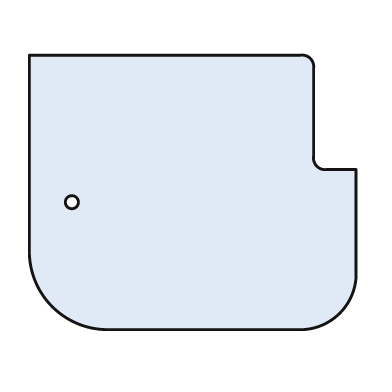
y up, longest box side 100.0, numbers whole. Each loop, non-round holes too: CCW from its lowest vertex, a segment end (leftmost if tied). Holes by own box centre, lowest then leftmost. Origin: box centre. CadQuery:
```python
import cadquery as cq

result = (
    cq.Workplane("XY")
    .moveTo(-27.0, -42.0)
    .lineTo(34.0, -42.0)
    .threePointArc((45.0, -37.0), (50.0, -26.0))
    .lineTo(50.0, 7.0)
    .lineTo(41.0, 7.0)
    .threePointArc((38.0, 8.0), (37.0, 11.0))
    .lineTo(37.0, 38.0)
    .threePointArc((36.0, 41.0), (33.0, 42.0))
    .lineTo(-50.0, 42.0)
    .lineTo(-50.0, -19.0)
    .threePointArc((-43.0, -35.0), (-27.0, -42.0))
    .close()
    .moveTo(-37.0, -3.0)
    .circle(2.0)
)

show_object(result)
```